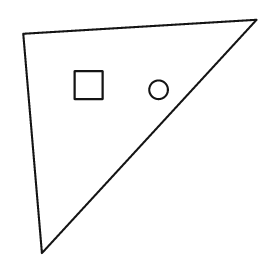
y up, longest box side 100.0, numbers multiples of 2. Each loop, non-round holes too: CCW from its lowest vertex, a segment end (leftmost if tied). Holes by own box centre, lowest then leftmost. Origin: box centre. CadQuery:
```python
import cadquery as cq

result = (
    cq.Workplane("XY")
    .moveTo(-42.0, -50.0)
    .lineTo(50.0, 50.0)
    .lineTo(-50.0, 44.0)
    .close()
    .moveTo(8.0, 20.0)
    .circle(4.0)
    .moveTo(-28.0, 16.0)
    .lineTo(-16.0, 16.0)
    .lineTo(-16.0, 28.0)
    .lineTo(-28.0, 28.0)
    .close()
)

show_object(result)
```